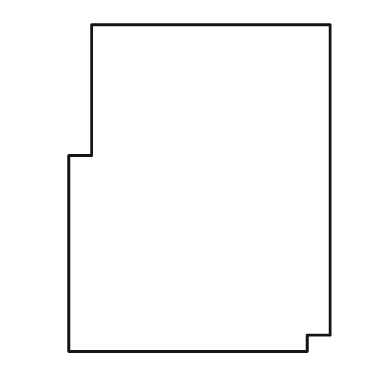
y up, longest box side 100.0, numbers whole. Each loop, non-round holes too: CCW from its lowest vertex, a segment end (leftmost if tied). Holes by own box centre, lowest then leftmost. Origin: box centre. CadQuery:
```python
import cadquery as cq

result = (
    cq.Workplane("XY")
    .moveTo(-40.0, -50.0)
    .lineTo(33.0, -50.0)
    .lineTo(33.0, -45.0)
    .lineTo(40.0, -45.0)
    .lineTo(40.0, 50.0)
    .lineTo(-33.0, 50.0)
    .lineTo(-33.0, 10.0)
    .lineTo(-40.0, 10.0)
    .close()
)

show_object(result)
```